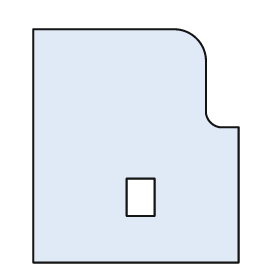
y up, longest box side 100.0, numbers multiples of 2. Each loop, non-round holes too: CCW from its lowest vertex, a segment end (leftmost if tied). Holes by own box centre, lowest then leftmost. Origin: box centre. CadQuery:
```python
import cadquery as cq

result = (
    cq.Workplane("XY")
    .moveTo(-44.0, -50.0)
    .lineTo(44.0, -50.0)
    .lineTo(44.0, 8.0)
    .lineTo(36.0, 8.0)
    .threePointArc((32.0, 10.0), (30.0, 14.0))
    .lineTo(30.0, 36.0)
    .threePointArc((26.0, 46.0), (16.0, 50.0))
    .lineTo(-44.0, 50.0)
    .close()
    .moveTo(-4.0, -30.0)
    .lineTo(8.0, -30.0)
    .lineTo(8.0, -14.0)
    .lineTo(-4.0, -14.0)
    .close()
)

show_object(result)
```